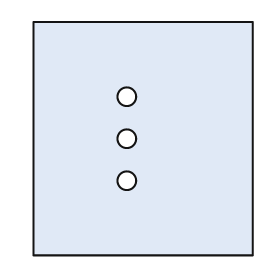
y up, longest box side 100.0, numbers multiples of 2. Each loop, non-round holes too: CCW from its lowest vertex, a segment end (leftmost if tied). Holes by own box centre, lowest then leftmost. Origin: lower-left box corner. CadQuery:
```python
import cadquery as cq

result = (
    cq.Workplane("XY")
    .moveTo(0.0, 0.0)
    .lineTo(94.0, 0.0)
    .lineTo(94.0, 100.0)
    .lineTo(0.0, 100.0)
    .close()
    .moveTo(40.0, 32.0)
    .circle(4.0)
    .moveTo(40.0, 50.0)
    .circle(4.0)
    .moveTo(40.0, 68.0)
    .circle(4.0)
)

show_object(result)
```